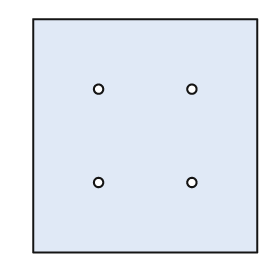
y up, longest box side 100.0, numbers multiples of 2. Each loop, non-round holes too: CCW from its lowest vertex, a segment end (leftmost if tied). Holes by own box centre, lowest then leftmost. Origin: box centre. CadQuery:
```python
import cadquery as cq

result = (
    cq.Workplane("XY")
    .moveTo(-48.0, -50.0)
    .lineTo(48.0, -50.0)
    .lineTo(48.0, 50.0)
    .lineTo(-48.0, 50.0)
    .close()
    .moveTo(-20.0, -20.0)
    .circle(2.0)
    .moveTo(20.0, -20.0)
    .circle(2.0)
    .moveTo(-20.0, 20.0)
    .circle(2.0)
    .moveTo(20.0, 20.0)
    .circle(2.0)
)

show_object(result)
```